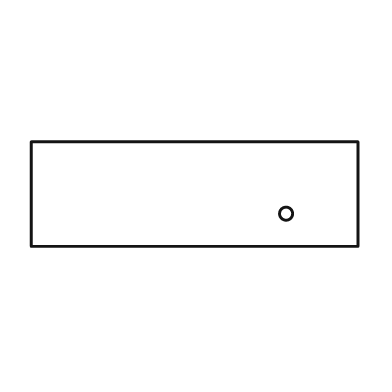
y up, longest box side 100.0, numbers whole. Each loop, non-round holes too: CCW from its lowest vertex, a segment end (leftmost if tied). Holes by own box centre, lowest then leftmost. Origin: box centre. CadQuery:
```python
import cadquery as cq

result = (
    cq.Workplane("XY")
    .moveTo(-50.0, -16.0)
    .lineTo(50.0, -16.0)
    .lineTo(50.0, 16.0)
    .lineTo(-50.0, 16.0)
    .close()
    .moveTo(28.0, -6.0)
    .circle(2.0)
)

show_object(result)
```